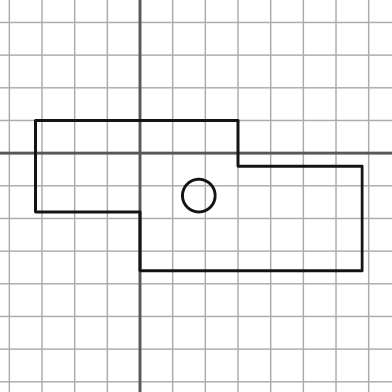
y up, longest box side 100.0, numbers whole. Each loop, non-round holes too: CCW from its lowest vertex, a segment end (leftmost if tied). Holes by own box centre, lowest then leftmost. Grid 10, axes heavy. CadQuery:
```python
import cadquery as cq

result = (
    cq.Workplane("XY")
    .moveTo(0.0, -36.0)
    .lineTo(68.0, -36.0)
    .lineTo(68.0, -4.0)
    .lineTo(30.0, -4.0)
    .lineTo(30.0, 10.0)
    .lineTo(-32.0, 10.0)
    .lineTo(-32.0, -18.0)
    .lineTo(0.0, -18.0)
    .close()
    .moveTo(18.0, -13.0)
    .circle(5.0)
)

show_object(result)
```